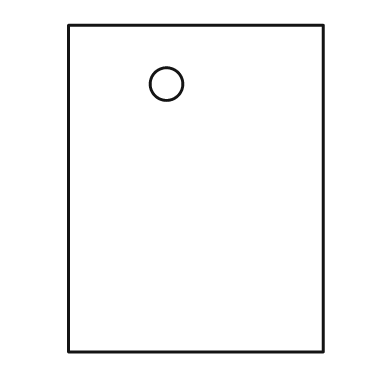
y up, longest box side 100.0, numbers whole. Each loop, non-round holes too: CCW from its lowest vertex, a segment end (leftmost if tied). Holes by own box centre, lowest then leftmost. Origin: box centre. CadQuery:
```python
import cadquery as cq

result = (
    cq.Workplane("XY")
    .moveTo(-39.0, -50.0)
    .lineTo(39.0, -50.0)
    .lineTo(39.0, 50.0)
    .lineTo(-39.0, 50.0)
    .close()
    .moveTo(-9.0, 32.0)
    .circle(5.0)
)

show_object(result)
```